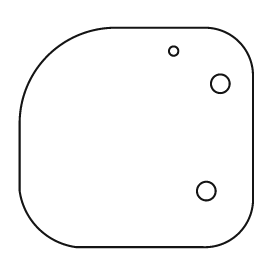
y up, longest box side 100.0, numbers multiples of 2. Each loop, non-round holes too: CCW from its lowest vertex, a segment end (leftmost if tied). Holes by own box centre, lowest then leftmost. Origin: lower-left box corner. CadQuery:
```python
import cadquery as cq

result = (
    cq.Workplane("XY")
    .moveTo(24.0, 0.0)
    .lineTo(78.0, 0.0)
    .threePointArc((94.0, 6.0), (100.0, 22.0))
    .lineTo(100.0, 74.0)
    .threePointArc((94.0, 88.0), (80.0, 94.0))
    .lineTo(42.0, 94.0)
    .threePointArc((12.0, 82.0), (0.0, 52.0))
    .lineTo(0.0, 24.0)
    .threePointArc((8.0, 8.0), (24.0, 0.0))
    .close()
    .moveTo(80.0, 24.0)
    .circle(4.0)
    .moveTo(86.0, 70.0)
    .circle(4.0)
    .moveTo(66.0, 84.0)
    .circle(2.0)
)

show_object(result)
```